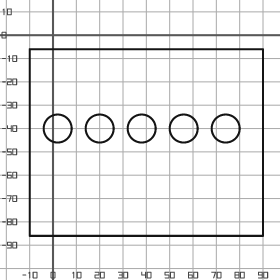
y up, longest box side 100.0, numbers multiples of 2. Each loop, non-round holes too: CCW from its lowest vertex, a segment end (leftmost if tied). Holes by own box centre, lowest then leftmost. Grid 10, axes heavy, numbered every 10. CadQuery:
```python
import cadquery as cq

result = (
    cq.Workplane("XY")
    .moveTo(-10.0, -86.0)
    .lineTo(90.0, -86.0)
    .lineTo(90.0, -6.0)
    .lineTo(-10.0, -6.0)
    .close()
    .moveTo(2.0, -40.0)
    .circle(6.0)
    .moveTo(20.0, -40.0)
    .circle(6.0)
    .moveTo(38.0, -40.0)
    .circle(6.0)
    .moveTo(56.0, -40.0)
    .circle(6.0)
    .moveTo(74.0, -40.0)
    .circle(6.0)
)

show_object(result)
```